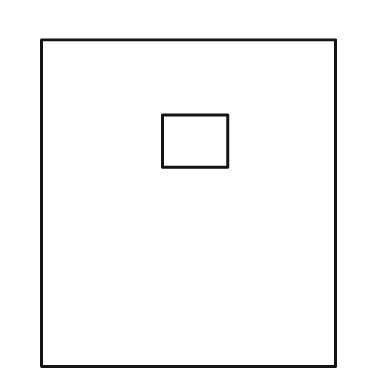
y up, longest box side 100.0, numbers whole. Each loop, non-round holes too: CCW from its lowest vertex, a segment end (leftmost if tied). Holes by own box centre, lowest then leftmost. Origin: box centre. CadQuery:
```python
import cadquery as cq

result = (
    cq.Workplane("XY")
    .moveTo(-45.0, -50.0)
    .lineTo(45.0, -50.0)
    .lineTo(45.0, 50.0)
    .lineTo(-45.0, 50.0)
    .close()
    .moveTo(-8.0, 11.0)
    .lineTo(12.0, 11.0)
    .lineTo(12.0, 27.0)
    .lineTo(-8.0, 27.0)
    .close()
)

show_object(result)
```